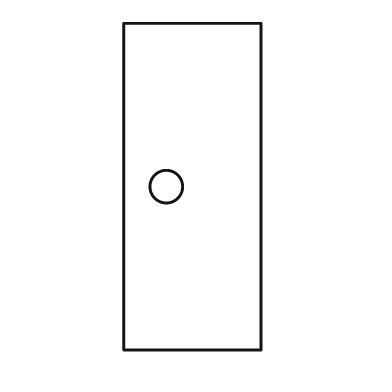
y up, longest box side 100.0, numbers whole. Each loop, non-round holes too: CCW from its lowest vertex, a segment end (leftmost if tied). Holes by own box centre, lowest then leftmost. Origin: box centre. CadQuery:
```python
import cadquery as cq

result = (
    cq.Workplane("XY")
    .moveTo(-21.0, -50.0)
    .lineTo(21.0, -50.0)
    .lineTo(21.0, 50.0)
    .lineTo(-21.0, 50.0)
    .close()
    .moveTo(-8.0, 0.0)
    .circle(5.0)
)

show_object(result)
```